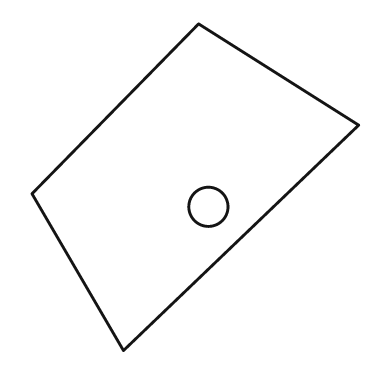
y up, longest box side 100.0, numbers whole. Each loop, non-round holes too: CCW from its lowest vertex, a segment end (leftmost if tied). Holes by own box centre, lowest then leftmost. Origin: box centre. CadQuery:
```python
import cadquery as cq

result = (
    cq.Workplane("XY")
    .moveTo(-22.0, -50.0)
    .lineTo(50.0, 19.0)
    .lineTo(1.0, 50.0)
    .lineTo(-50.0, -2.0)
    .close()
    .moveTo(4.0, -6.0)
    .circle(6.0)
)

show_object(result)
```